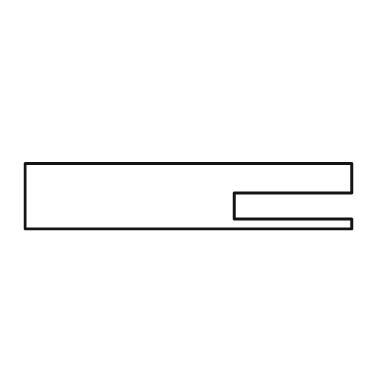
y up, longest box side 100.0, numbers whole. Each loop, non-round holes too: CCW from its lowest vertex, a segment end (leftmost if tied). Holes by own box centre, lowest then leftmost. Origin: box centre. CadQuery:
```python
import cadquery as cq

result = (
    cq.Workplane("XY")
    .moveTo(-50.0, -10.0)
    .lineTo(50.0, -10.0)
    .lineTo(50.0, -7.0)
    .lineTo(14.0, -7.0)
    .lineTo(14.0, 1.0)
    .lineTo(50.0, 1.0)
    .lineTo(50.0, 10.0)
    .lineTo(-50.0, 10.0)
    .close()
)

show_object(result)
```